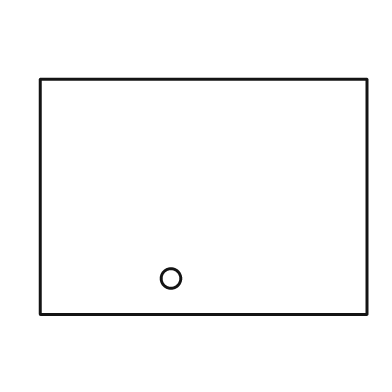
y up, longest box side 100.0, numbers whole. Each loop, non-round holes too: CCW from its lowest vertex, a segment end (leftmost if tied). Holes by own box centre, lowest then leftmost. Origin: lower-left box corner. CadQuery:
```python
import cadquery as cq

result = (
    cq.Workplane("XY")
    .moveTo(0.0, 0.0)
    .lineTo(100.0, 0.0)
    .lineTo(100.0, 72.0)
    .lineTo(0.0, 72.0)
    .close()
    .moveTo(40.0, 11.0)
    .circle(3.0)
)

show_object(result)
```